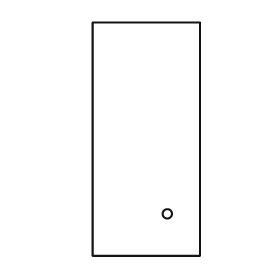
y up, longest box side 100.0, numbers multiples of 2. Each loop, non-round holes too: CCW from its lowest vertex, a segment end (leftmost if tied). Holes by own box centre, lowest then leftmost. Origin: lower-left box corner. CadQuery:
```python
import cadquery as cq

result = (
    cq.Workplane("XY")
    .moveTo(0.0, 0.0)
    .lineTo(46.0, 0.0)
    .lineTo(46.0, 100.0)
    .lineTo(0.0, 100.0)
    .close()
    .moveTo(32.0, 18.0)
    .circle(2.0)
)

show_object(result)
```